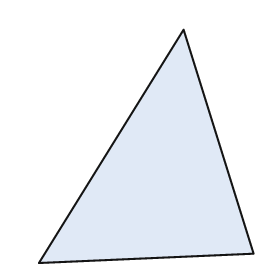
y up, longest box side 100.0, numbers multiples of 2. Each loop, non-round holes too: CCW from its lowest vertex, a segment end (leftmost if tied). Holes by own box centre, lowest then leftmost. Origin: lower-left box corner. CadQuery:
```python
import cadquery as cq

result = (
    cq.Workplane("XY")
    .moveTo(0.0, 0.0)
    .lineTo(92.0, 4.0)
    .lineTo(62.0, 100.0)
    .close()
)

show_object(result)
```